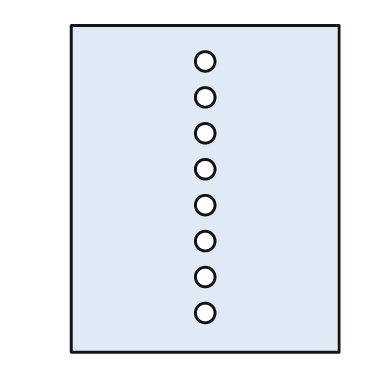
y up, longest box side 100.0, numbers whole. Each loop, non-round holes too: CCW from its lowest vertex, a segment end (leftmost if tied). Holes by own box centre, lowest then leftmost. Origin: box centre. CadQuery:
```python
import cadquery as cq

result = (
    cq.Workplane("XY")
    .moveTo(-41.0, -50.0)
    .lineTo(41.0, -50.0)
    .lineTo(41.0, 50.0)
    .lineTo(-41.0, 50.0)
    .close()
    .moveTo(0.0, -38.0)
    .circle(3.0)
    .moveTo(0.0, -27.0)
    .circle(3.0)
    .moveTo(0.0, -16.0)
    .circle(3.0)
    .moveTo(0.0, -5.0)
    .circle(3.0)
    .moveTo(0.0, 6.0)
    .circle(3.0)
    .moveTo(0.0, 17.0)
    .circle(3.0)
    .moveTo(0.0, 28.0)
    .circle(3.0)
    .moveTo(0.0, 39.0)
    .circle(3.0)
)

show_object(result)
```